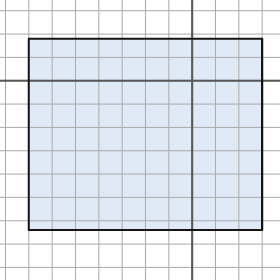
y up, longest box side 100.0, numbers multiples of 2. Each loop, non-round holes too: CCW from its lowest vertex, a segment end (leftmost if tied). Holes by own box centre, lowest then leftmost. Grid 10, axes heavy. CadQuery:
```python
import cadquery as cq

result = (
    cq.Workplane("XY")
    .moveTo(-70.0, -64.0)
    .lineTo(30.0, -64.0)
    .lineTo(30.0, 18.0)
    .lineTo(-70.0, 18.0)
    .close()
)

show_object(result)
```